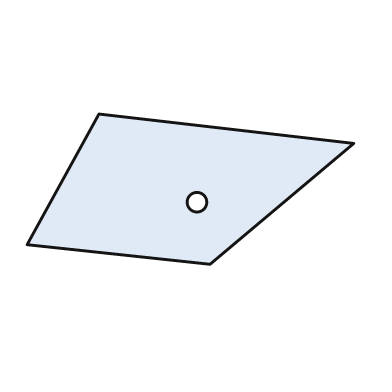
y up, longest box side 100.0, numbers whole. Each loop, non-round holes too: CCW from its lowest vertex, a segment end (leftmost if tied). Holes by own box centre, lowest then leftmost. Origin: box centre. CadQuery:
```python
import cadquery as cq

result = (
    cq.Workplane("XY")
    .moveTo(6.0, -23.0)
    .lineTo(50.0, 14.0)
    .lineTo(-28.0, 23.0)
    .lineTo(-50.0, -17.0)
    .close()
    .moveTo(2.0, -4.0)
    .circle(3.0)
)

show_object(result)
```